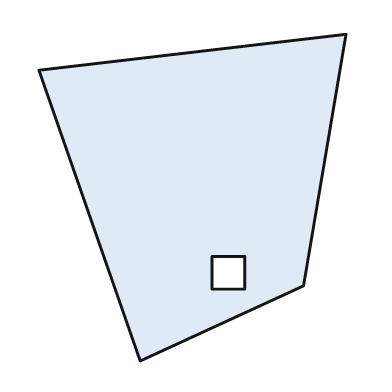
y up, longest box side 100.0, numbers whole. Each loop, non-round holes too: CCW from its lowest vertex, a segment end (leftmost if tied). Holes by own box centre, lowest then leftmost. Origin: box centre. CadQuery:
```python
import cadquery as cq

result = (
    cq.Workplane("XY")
    .moveTo(-16.0, -50.0)
    .lineTo(34.0, -27.0)
    .lineTo(47.0, 50.0)
    .lineTo(-47.0, 39.0)
    .close()
    .moveTo(6.0, -28.0)
    .lineTo(16.0, -28.0)
    .lineTo(16.0, -18.0)
    .lineTo(6.0, -18.0)
    .close()
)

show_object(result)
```